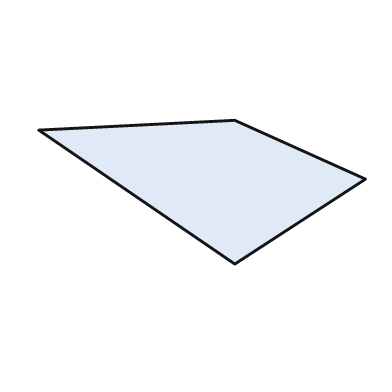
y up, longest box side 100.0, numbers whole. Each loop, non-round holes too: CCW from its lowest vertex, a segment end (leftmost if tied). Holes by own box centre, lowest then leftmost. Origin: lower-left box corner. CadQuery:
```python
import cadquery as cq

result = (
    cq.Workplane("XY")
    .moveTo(60.0, 0.0)
    .lineTo(100.0, 26.0)
    .lineTo(60.0, 44.0)
    .lineTo(0.0, 41.0)
    .close()
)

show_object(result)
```